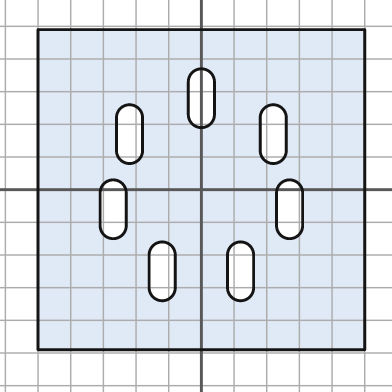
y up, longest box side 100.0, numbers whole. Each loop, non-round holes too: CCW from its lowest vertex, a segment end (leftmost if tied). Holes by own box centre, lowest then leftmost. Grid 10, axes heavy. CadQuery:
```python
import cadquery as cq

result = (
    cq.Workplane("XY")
    .moveTo(-50.0, -49.0)
    .lineTo(50.0, -49.0)
    .lineTo(50.0, 49.0)
    .lineTo(-50.0, 49.0)
    .close()
    .moveTo(-16.0, -30.0)
    .threePointArc((-12.0, -34.0), (-8.0, -30.0))
    .lineTo(-8.0, -20.0)
    .threePointArc((-12.0, -16.0), (-16.0, -20.0))
    .close()
    .moveTo(8.0, -30.0)
    .threePointArc((12.0, -34.0), (16.0, -30.0))
    .lineTo(16.0, -20.0)
    .threePointArc((12.0, -16.0), (8.0, -20.0))
    .close()
    .moveTo(-31.0, -11.0)
    .threePointArc((-27.0, -15.0), (-23.0, -11.0))
    .lineTo(-23.0, -1.0)
    .threePointArc((-27.0, 3.0), (-31.0, -1.0))
    .close()
    .moveTo(23.0, -11.0)
    .threePointArc((27.0, -15.0), (31.0, -11.0))
    .lineTo(31.0, -1.0)
    .threePointArc((27.0, 3.0), (23.0, -1.0))
    .close()
    .moveTo(-26.0, 12.0)
    .threePointArc((-22.0, 8.0), (-18.0, 12.0))
    .lineTo(-18.0, 22.0)
    .threePointArc((-22.0, 26.0), (-26.0, 22.0))
    .close()
    .moveTo(18.0, 12.0)
    .threePointArc((22.0, 8.0), (26.0, 12.0))
    .lineTo(26.0, 22.0)
    .threePointArc((22.0, 26.0), (18.0, 22.0))
    .close()
    .moveTo(-4.0, 23.0)
    .threePointArc((0.0, 19.0), (4.0, 23.0))
    .lineTo(4.0, 33.0)
    .threePointArc((0.0, 37.0), (-4.0, 33.0))
    .close()
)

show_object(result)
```